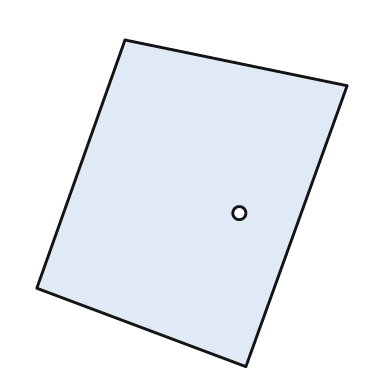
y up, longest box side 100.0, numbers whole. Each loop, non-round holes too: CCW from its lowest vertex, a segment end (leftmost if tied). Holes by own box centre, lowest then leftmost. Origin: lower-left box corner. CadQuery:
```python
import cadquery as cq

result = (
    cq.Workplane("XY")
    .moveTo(64.0, 0.0)
    .lineTo(95.0, 86.0)
    .lineTo(27.0, 100.0)
    .lineTo(0.0, 24.0)
    .close()
    .moveTo(62.0, 47.0)
    .circle(2.0)
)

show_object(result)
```